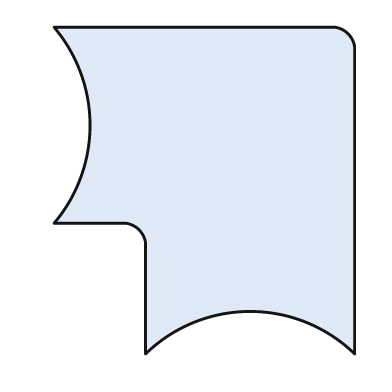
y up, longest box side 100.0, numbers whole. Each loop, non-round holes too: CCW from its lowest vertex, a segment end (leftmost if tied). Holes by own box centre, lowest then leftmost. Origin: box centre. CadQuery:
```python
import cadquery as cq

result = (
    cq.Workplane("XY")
    .moveTo(-18.0, -50.0)
    .threePointArc((14.0, -37.0), (46.0, -50.0))
    .lineTo(46.0, 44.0)
    .threePointArc((44.0, 48.0), (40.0, 50.0))
    .lineTo(-46.0, 50.0)
    .threePointArc((-35.0, 20.0), (-46.0, -10.0))
    .lineTo(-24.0, -10.0)
    .threePointArc((-20.0, -12.0), (-18.0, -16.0))
    .close()
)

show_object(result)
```